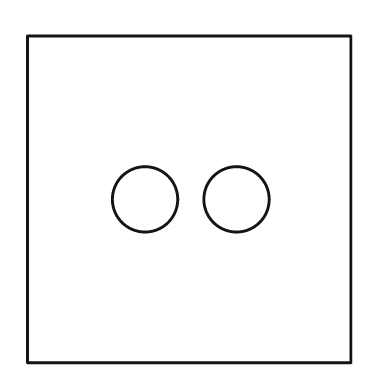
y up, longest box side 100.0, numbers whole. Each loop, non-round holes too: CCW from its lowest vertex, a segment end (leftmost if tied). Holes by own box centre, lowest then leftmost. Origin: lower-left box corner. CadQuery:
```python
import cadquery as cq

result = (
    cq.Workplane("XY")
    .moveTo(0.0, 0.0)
    .lineTo(99.0, 0.0)
    .lineTo(99.0, 100.0)
    .lineTo(0.0, 100.0)
    .close()
    .moveTo(36.0, 50.0)
    .circle(10.0)
    .moveTo(64.0, 50.0)
    .circle(10.0)
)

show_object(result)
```